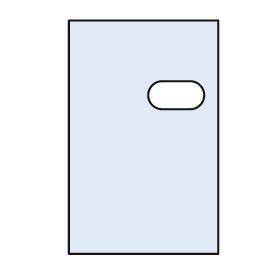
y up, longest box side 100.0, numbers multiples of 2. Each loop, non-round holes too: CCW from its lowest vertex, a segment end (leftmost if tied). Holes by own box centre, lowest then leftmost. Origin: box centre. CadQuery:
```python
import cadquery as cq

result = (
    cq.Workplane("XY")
    .moveTo(-32.0, -50.0)
    .lineTo(32.0, -50.0)
    .lineTo(32.0, 50.0)
    .lineTo(-32.0, 50.0)
    .close()
    .moveTo(8.0, 12.0)
    .lineTo(20.0, 12.0)
    .threePointArc((26.0, 18.0), (20.0, 24.0))
    .lineTo(8.0, 24.0)
    .threePointArc((2.0, 18.0), (8.0, 12.0))
    .close()
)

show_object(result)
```